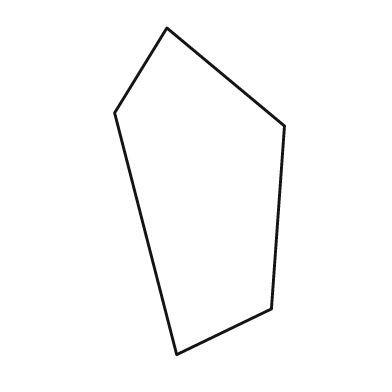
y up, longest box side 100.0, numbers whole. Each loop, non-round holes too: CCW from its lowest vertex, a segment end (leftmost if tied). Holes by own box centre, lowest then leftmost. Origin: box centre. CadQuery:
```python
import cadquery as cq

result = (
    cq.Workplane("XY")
    .moveTo(-7.0, -50.0)
    .lineTo(22.0, -36.0)
    .lineTo(26.0, 20.0)
    .lineTo(-10.0, 50.0)
    .lineTo(-26.0, 24.0)
    .close()
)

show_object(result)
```